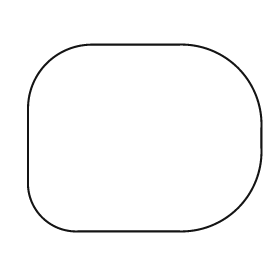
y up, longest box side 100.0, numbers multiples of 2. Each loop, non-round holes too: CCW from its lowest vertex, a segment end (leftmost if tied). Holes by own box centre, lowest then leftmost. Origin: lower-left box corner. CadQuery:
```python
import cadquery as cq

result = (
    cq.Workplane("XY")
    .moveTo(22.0, 0.0)
    .lineTo(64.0, 0.0)
    .threePointArc((90.0, 10.0), (100.0, 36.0))
    .lineTo(100.0, 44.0)
    .threePointArc((90.0, 70.0), (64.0, 80.0))
    .lineTo(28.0, 80.0)
    .threePointArc((8.0, 72.0), (0.0, 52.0))
    .lineTo(0.0, 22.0)
    .threePointArc((6.0, 6.0), (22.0, 0.0))
    .close()
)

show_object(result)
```